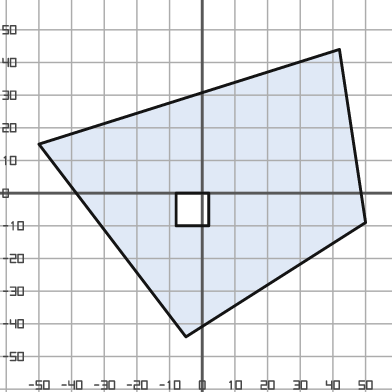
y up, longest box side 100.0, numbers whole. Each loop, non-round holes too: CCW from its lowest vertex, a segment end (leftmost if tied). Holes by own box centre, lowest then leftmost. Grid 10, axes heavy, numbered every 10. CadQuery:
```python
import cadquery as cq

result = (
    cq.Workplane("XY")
    .moveTo(-5.0, -44.0)
    .lineTo(50.0, -9.0)
    .lineTo(42.0, 44.0)
    .lineTo(-50.0, 15.0)
    .close()
    .moveTo(-8.0, -10.0)
    .lineTo(2.0, -10.0)
    .lineTo(2.0, 0.0)
    .lineTo(-8.0, 0.0)
    .close()
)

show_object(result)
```